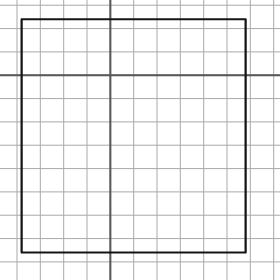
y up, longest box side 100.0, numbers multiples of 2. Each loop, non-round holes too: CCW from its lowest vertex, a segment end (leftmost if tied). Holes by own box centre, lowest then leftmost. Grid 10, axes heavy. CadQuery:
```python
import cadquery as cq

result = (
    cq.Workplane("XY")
    .moveTo(-38.0, -76.0)
    .lineTo(58.0, -76.0)
    .lineTo(58.0, 24.0)
    .lineTo(-38.0, 24.0)
    .close()
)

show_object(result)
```